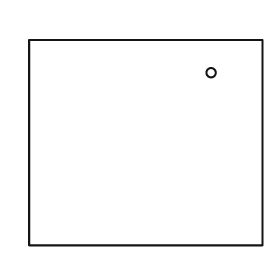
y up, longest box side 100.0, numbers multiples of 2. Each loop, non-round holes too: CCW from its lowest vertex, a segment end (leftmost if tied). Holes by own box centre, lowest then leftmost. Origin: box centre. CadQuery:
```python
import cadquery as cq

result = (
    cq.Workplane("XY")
    .moveTo(-50.0, -44.0)
    .lineTo(50.0, -44.0)
    .lineTo(50.0, 44.0)
    .lineTo(-50.0, 44.0)
    .close()
    .moveTo(28.0, 30.0)
    .circle(2.0)
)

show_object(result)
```